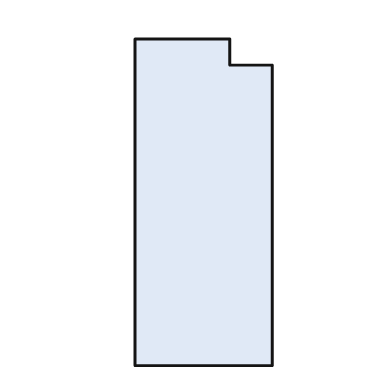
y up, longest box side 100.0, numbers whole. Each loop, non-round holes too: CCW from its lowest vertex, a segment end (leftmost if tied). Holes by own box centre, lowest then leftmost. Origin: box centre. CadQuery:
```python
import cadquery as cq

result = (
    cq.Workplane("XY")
    .moveTo(-21.0, -50.0)
    .lineTo(21.0, -50.0)
    .lineTo(21.0, 42.0)
    .lineTo(8.0, 42.0)
    .lineTo(8.0, 50.0)
    .lineTo(-21.0, 50.0)
    .close()
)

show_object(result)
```